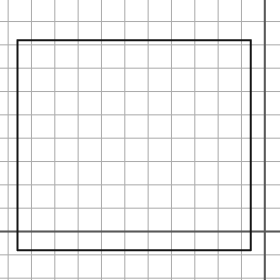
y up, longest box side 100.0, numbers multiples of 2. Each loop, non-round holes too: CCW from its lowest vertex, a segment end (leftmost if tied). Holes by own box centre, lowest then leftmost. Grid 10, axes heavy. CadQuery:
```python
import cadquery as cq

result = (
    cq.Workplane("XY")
    .moveTo(-106.0, -8.0)
    .lineTo(-6.0, -8.0)
    .lineTo(-6.0, 82.0)
    .lineTo(-106.0, 82.0)
    .close()
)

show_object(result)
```